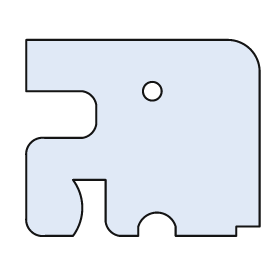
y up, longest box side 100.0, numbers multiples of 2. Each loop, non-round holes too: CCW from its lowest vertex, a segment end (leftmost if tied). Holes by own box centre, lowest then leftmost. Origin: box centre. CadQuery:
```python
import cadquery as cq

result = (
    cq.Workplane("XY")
    .moveTo(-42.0, -42.0)
    .lineTo(-30.0, -42.0)
    .threePointArc((-26.0, -30.0), (-30.0, -18.0))
    .lineTo(-16.0, -18.0)
    .lineTo(-16.0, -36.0)
    .threePointArc((-14.0, -40.0), (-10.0, -42.0))
    .lineTo(-2.0, -42.0)
    .lineTo(-2.0, -38.0)
    .threePointArc((6.0, -32.0), (14.0, -38.0))
    .lineTo(14.0, -42.0)
    .lineTo(40.0, -42.0)
    .lineTo(40.0, -38.0)
    .lineTo(50.0, -38.0)
    .lineTo(50.0, 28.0)
    .threePointArc((46.0, 38.0), (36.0, 42.0))
    .lineTo(-50.0, 42.0)
    .lineTo(-50.0, 20.0)
    .lineTo(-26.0, 20.0)
    .threePointArc((-22.0, 18.0), (-20.0, 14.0))
    .lineTo(-20.0, 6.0)
    .threePointArc((-22.0, 2.0), (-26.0, 0.0))
    .lineTo(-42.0, 0.0)
    .threePointArc((-48.0, -2.0), (-50.0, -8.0))
    .lineTo(-50.0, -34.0)
    .threePointArc((-48.0, -40.0), (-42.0, -42.0))
    .close()
    .moveTo(4.0, 20.0)
    .circle(4.0)
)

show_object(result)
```